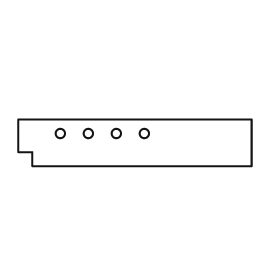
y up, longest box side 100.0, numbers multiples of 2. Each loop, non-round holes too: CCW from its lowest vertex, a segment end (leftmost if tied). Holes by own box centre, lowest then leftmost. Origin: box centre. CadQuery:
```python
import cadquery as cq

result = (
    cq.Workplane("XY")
    .moveTo(-44.0, -10.0)
    .lineTo(50.0, -10.0)
    .lineTo(50.0, 10.0)
    .lineTo(-50.0, 10.0)
    .lineTo(-50.0, -4.0)
    .lineTo(-44.0, -4.0)
    .close()
    .moveTo(-32.0, 4.0)
    .circle(2.0)
    .moveTo(-20.0, 4.0)
    .circle(2.0)
    .moveTo(-8.0, 4.0)
    .circle(2.0)
    .moveTo(4.0, 4.0)
    .circle(2.0)
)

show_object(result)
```